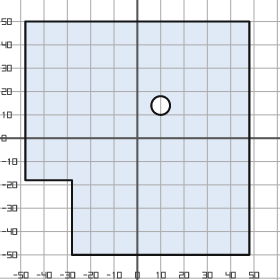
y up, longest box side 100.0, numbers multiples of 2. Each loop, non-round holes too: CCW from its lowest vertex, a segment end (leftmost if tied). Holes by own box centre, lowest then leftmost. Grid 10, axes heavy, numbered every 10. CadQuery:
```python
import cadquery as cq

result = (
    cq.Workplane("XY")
    .moveTo(-28.0, -50.0)
    .lineTo(48.0, -50.0)
    .lineTo(48.0, 50.0)
    .lineTo(-48.0, 50.0)
    .lineTo(-48.0, -18.0)
    .lineTo(-28.0, -18.0)
    .close()
    .moveTo(10.0, 14.0)
    .circle(4.0)
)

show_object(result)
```